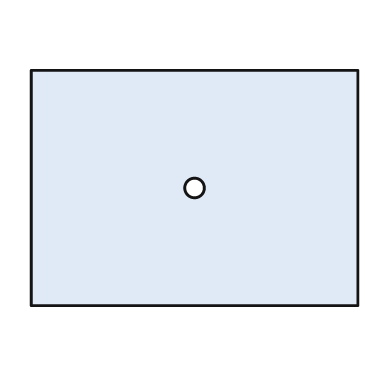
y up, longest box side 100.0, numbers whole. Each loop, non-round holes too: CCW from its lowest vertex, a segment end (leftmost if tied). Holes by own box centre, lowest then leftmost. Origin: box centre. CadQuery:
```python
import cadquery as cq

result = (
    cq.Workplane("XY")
    .moveTo(-50.0, -36.0)
    .lineTo(50.0, -36.0)
    .lineTo(50.0, 36.0)
    .lineTo(-50.0, 36.0)
    .close()
    .moveTo(0.0, 0.0)
    .circle(3.0)
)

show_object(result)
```